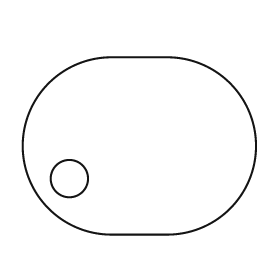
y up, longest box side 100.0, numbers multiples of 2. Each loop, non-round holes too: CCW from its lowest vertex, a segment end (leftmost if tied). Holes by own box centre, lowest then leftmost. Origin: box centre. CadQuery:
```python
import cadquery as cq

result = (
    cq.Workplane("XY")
    .moveTo(-12.0, -38.0)
    .lineTo(12.0, -38.0)
    .threePointArc((50.0, 0.0), (12.0, 38.0))
    .lineTo(-12.0, 38.0)
    .threePointArc((-50.0, 0.0), (-12.0, -38.0))
    .close()
    .moveTo(-30.0, -14.0)
    .circle(8.0)
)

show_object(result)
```